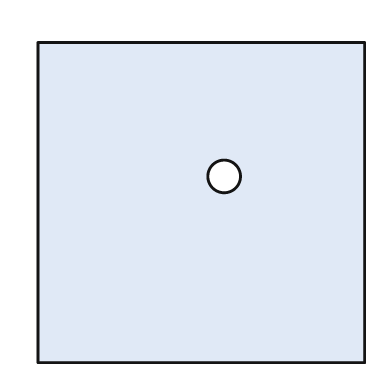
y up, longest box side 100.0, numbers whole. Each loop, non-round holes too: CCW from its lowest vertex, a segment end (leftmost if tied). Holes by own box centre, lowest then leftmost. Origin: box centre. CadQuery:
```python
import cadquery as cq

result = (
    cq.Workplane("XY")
    .moveTo(-50.0, -49.0)
    .lineTo(50.0, -49.0)
    .lineTo(50.0, 49.0)
    .lineTo(-50.0, 49.0)
    .close()
    .moveTo(7.0, 8.0)
    .circle(5.0)
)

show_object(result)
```